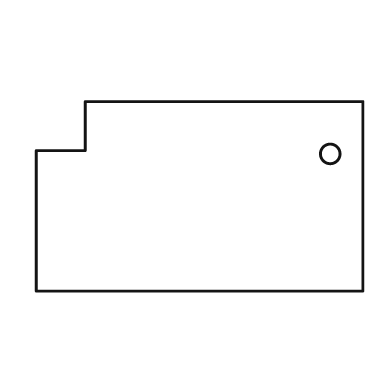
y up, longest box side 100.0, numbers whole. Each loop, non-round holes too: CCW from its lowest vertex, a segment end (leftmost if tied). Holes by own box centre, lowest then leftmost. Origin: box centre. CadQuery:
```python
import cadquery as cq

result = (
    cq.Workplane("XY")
    .moveTo(-50.0, -29.0)
    .lineTo(50.0, -29.0)
    .lineTo(50.0, 29.0)
    .lineTo(-35.0, 29.0)
    .lineTo(-35.0, 14.0)
    .lineTo(-50.0, 14.0)
    .close()
    .moveTo(40.0, 13.0)
    .circle(3.0)
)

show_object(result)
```